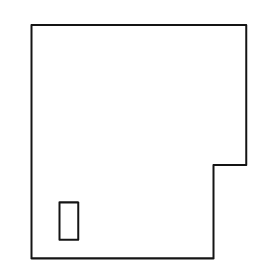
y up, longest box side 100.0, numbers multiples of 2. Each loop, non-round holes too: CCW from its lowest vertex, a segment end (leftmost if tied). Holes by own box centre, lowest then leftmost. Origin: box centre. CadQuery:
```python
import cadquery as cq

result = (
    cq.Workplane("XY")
    .moveTo(-46.0, -50.0)
    .lineTo(32.0, -50.0)
    .lineTo(32.0, -10.0)
    .lineTo(46.0, -10.0)
    .lineTo(46.0, 50.0)
    .lineTo(-46.0, 50.0)
    .close()
    .moveTo(-34.0, -42.0)
    .lineTo(-26.0, -42.0)
    .lineTo(-26.0, -26.0)
    .lineTo(-34.0, -26.0)
    .close()
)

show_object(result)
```